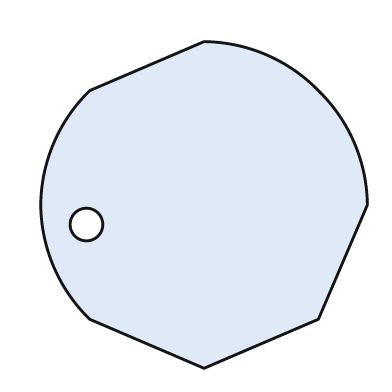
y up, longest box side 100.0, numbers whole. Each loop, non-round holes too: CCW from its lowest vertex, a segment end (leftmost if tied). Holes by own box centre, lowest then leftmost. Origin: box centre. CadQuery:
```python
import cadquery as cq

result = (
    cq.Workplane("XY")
    .moveTo(0.0, -50.0)
    .lineTo(35.0, -35.0)
    .lineTo(50.0, 0.0)
    .threePointArc((46.0, 19.0), (35.0, 35.0))
    .threePointArc((19.0, 46.0), (0.0, 50.0))
    .lineTo(-35.0, 35.0)
    .threePointArc((-46.0, 19.0), (-50.0, 0.0))
    .threePointArc((-46.0, -19.0), (-35.0, -35.0))
    .close()
    .moveTo(-36.0, -6.0)
    .circle(5.0)
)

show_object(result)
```